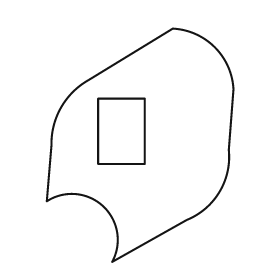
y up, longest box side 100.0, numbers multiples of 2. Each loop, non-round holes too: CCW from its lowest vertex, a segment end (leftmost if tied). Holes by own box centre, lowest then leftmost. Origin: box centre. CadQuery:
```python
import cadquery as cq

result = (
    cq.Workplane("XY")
    .moveTo(-12.0, -50.0)
    .lineTo(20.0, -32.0)
    .threePointArc((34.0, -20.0), (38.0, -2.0))
    .lineTo(40.0, 24.0)
    .threePointArc((32.0, 42.0), (14.0, 50.0))
    .lineTo(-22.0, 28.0)
    .threePointArc((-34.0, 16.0), (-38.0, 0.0))
    .lineTo(-40.0, -24.0)
    .threePointArc((-16.0, -26.0), (-12.0, -50.0))
    .close()
    .moveTo(-18.0, -8.0)
    .lineTo(2.0, -8.0)
    .lineTo(2.0, 20.0)
    .lineTo(-18.0, 20.0)
    .close()
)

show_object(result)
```